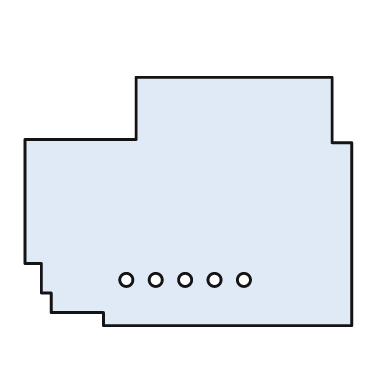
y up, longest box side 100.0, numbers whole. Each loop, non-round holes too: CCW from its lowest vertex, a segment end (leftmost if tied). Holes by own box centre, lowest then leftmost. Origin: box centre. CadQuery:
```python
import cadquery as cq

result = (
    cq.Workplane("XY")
    .moveTo(-26.0, -38.0)
    .lineTo(50.0, -38.0)
    .lineTo(50.0, 18.0)
    .lineTo(44.0, 18.0)
    .lineTo(44.0, 38.0)
    .lineTo(-16.0, 38.0)
    .lineTo(-16.0, 19.0)
    .lineTo(-50.0, 19.0)
    .lineTo(-50.0, -19.0)
    .lineTo(-45.0, -19.0)
    .lineTo(-45.0, -28.0)
    .lineTo(-42.0, -28.0)
    .lineTo(-42.0, -34.0)
    .lineTo(-26.0, -34.0)
    .close()
    .moveTo(-19.0, -24.0)
    .circle(2.0)
    .moveTo(-10.0, -24.0)
    .circle(2.0)
    .moveTo(-1.0, -24.0)
    .circle(2.0)
    .moveTo(8.0, -24.0)
    .circle(2.0)
    .moveTo(17.0, -24.0)
    .circle(2.0)
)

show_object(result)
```